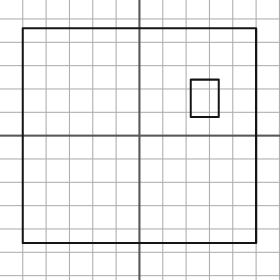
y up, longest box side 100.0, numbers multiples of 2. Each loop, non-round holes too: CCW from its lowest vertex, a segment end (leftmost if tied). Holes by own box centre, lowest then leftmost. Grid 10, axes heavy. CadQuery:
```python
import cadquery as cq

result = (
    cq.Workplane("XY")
    .moveTo(-50.0, -46.0)
    .lineTo(50.0, -46.0)
    .lineTo(50.0, 46.0)
    .lineTo(-50.0, 46.0)
    .close()
    .moveTo(22.0, 8.0)
    .lineTo(34.0, 8.0)
    .lineTo(34.0, 24.0)
    .lineTo(22.0, 24.0)
    .close()
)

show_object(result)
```